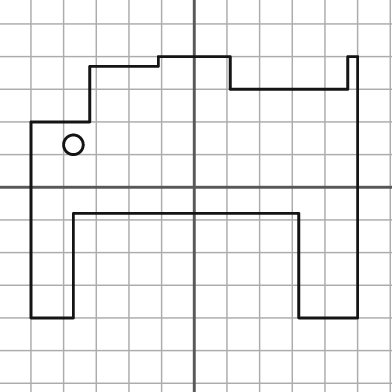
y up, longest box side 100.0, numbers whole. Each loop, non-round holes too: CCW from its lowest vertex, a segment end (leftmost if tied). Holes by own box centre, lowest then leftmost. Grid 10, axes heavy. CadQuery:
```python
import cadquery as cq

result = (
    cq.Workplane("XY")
    .moveTo(-50.0, -40.0)
    .lineTo(-37.0, -40.0)
    .lineTo(-37.0, -8.0)
    .lineTo(32.0, -8.0)
    .lineTo(32.0, -40.0)
    .lineTo(50.0, -40.0)
    .lineTo(50.0, 40.0)
    .lineTo(47.0, 40.0)
    .lineTo(47.0, 30.0)
    .lineTo(11.0, 30.0)
    .lineTo(11.0, 40.0)
    .lineTo(-11.0, 40.0)
    .lineTo(-11.0, 37.0)
    .lineTo(-32.0, 37.0)
    .lineTo(-32.0, 20.0)
    .lineTo(-50.0, 20.0)
    .close()
    .moveTo(-37.0, 13.0)
    .circle(3.0)
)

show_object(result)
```